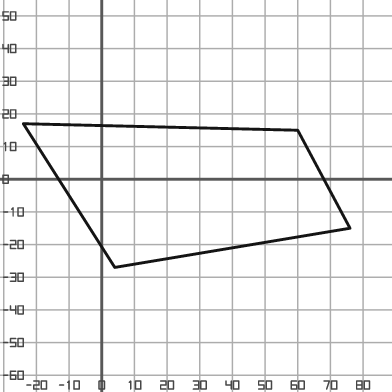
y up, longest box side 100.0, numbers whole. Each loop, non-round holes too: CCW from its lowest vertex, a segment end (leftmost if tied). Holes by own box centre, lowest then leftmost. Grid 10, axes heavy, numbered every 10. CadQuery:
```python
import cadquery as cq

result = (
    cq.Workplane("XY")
    .moveTo(4.0, -27.0)
    .lineTo(76.0, -15.0)
    .lineTo(60.0, 15.0)
    .lineTo(-24.0, 17.0)
    .close()
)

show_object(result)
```